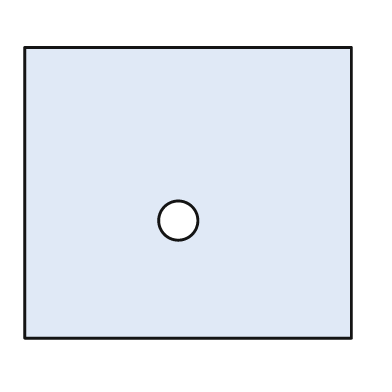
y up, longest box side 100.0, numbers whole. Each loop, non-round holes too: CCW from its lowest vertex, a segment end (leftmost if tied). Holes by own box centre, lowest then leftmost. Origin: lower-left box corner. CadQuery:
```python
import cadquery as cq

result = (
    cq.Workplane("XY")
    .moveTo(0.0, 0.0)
    .lineTo(100.0, 0.0)
    .lineTo(100.0, 89.0)
    .lineTo(0.0, 89.0)
    .close()
    .moveTo(47.0, 36.0)
    .circle(6.0)
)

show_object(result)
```